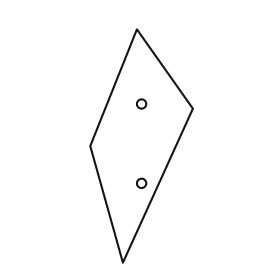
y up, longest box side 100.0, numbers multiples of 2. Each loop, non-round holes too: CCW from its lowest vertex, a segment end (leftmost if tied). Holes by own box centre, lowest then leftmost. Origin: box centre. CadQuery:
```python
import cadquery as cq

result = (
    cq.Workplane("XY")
    .moveTo(-8.0, -50.0)
    .lineTo(22.0, 16.0)
    .lineTo(-2.0, 50.0)
    .lineTo(-22.0, 0.0)
    .close()
    .moveTo(0.0, -16.0)
    .circle(2.0)
    .moveTo(0.0, 18.0)
    .circle(2.0)
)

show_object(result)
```